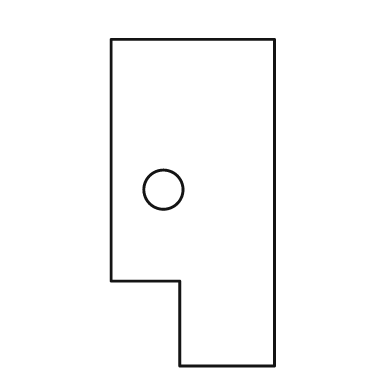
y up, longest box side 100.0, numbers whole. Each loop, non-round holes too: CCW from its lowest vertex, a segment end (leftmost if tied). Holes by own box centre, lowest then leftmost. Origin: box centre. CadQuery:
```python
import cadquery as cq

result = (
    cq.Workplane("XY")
    .moveTo(-4.0, -50.0)
    .lineTo(25.0, -50.0)
    .lineTo(25.0, 50.0)
    .lineTo(-25.0, 50.0)
    .lineTo(-25.0, -24.0)
    .lineTo(-4.0, -24.0)
    .close()
    .moveTo(-9.0, 4.0)
    .circle(6.0)
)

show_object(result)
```